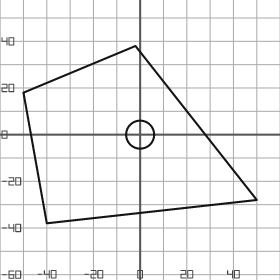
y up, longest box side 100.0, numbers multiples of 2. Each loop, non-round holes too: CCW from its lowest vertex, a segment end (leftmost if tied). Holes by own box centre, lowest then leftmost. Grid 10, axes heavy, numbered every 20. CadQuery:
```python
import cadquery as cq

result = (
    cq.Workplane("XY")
    .moveTo(-40.0, -38.0)
    .lineTo(50.0, -28.0)
    .lineTo(-2.0, 38.0)
    .lineTo(-50.0, 18.0)
    .close()
    .moveTo(0.0, 0.0)
    .circle(6.0)
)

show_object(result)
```